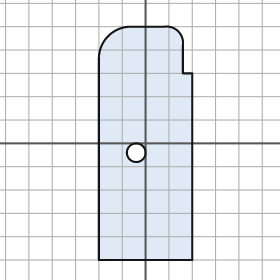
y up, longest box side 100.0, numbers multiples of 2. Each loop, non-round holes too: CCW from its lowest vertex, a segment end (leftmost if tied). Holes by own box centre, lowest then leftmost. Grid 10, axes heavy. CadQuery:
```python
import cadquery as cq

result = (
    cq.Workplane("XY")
    .moveTo(-20.0, -50.0)
    .lineTo(20.0, -50.0)
    .lineTo(20.0, 30.0)
    .lineTo(16.0, 30.0)
    .lineTo(16.0, 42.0)
    .threePointArc((14.0, 48.0), (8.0, 50.0))
    .lineTo(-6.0, 50.0)
    .threePointArc((-16.0, 46.0), (-20.0, 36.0))
    .close()
    .moveTo(-4.0, -4.0)
    .circle(4.0)
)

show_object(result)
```